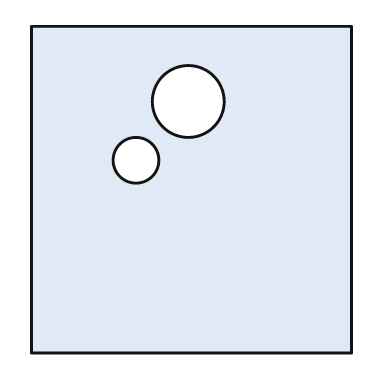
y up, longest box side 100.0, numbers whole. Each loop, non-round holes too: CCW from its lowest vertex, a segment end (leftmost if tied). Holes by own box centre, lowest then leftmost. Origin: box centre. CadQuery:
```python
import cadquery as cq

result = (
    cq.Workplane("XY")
    .moveTo(-49.0, -50.0)
    .lineTo(49.0, -50.0)
    .lineTo(49.0, 50.0)
    .lineTo(-49.0, 50.0)
    .close()
    .moveTo(-17.0, 9.0)
    .circle(7.0)
    .moveTo(-1.0, 27.0)
    .circle(11.0)
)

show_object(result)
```